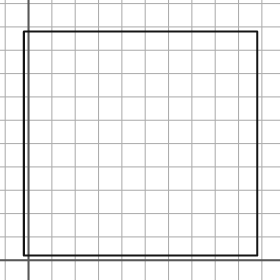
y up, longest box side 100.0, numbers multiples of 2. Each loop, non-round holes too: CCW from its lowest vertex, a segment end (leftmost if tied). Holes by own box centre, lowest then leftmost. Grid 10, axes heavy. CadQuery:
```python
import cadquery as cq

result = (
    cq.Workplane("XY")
    .moveTo(-2.0, 2.0)
    .lineTo(98.0, 2.0)
    .lineTo(98.0, 98.0)
    .lineTo(-2.0, 98.0)
    .close()
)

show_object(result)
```